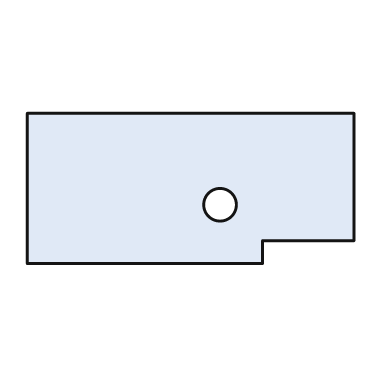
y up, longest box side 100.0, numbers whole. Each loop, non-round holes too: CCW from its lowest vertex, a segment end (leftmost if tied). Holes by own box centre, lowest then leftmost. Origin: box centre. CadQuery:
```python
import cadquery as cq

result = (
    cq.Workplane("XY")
    .moveTo(-50.0, -23.0)
    .lineTo(22.0, -23.0)
    .lineTo(22.0, -16.0)
    .lineTo(50.0, -16.0)
    .lineTo(50.0, 23.0)
    .lineTo(-50.0, 23.0)
    .close()
    .moveTo(9.0, -5.0)
    .circle(5.0)
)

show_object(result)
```